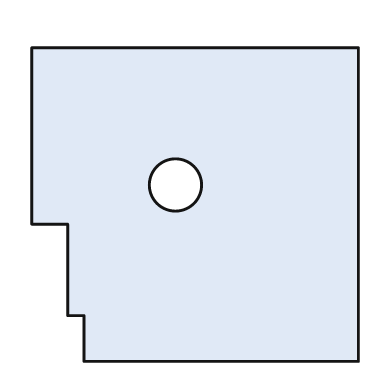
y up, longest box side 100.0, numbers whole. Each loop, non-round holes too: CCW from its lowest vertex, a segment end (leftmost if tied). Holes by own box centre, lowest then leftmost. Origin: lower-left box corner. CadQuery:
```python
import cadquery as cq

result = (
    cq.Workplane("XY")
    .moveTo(16.0, 0.0)
    .lineTo(100.0, 0.0)
    .lineTo(100.0, 96.0)
    .lineTo(0.0, 96.0)
    .lineTo(0.0, 42.0)
    .lineTo(11.0, 42.0)
    .lineTo(11.0, 14.0)
    .lineTo(16.0, 14.0)
    .close()
    .moveTo(44.0, 54.0)
    .circle(8.0)
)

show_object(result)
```